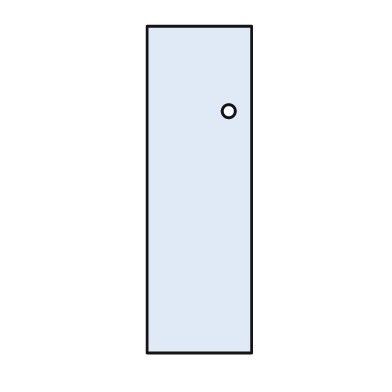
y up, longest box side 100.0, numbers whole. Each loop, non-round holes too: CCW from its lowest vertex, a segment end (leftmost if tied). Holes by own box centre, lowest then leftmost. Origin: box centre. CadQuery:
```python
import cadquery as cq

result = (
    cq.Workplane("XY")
    .moveTo(-16.0, -50.0)
    .lineTo(16.0, -50.0)
    .lineTo(16.0, 50.0)
    .lineTo(-16.0, 50.0)
    .close()
    .moveTo(9.0, 24.0)
    .circle(2.0)
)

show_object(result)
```